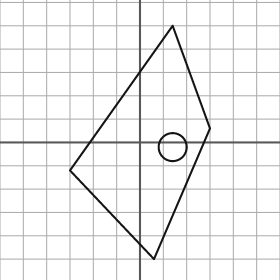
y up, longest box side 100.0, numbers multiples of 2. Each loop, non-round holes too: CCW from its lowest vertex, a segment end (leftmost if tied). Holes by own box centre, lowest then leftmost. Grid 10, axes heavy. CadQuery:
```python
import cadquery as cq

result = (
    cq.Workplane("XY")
    .moveTo(6.0, -50.0)
    .lineTo(30.0, 6.0)
    .lineTo(14.0, 50.0)
    .lineTo(-30.0, -12.0)
    .close()
    .moveTo(14.0, -2.0)
    .circle(6.0)
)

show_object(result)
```